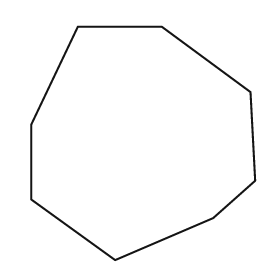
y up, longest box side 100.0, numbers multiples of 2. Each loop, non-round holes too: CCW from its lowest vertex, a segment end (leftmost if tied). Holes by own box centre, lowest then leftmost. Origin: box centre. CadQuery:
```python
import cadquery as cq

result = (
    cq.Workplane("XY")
    .moveTo(-12.0, -50.0)
    .lineTo(30.0, -32.0)
    .lineTo(48.0, -16.0)
    .lineTo(46.0, 22.0)
    .lineTo(8.0, 50.0)
    .lineTo(-28.0, 50.0)
    .lineTo(-48.0, 8.0)
    .lineTo(-48.0, -24.0)
    .close()
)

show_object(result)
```